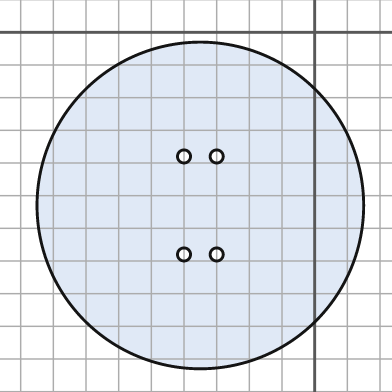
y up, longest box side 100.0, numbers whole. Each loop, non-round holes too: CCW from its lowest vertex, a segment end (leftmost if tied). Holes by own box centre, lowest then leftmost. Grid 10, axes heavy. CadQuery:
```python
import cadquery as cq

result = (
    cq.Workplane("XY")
    .moveTo(-35.0, -53.0)
    .circle(50.0)
    .moveTo(-40.0, -68.0)
    .circle(2.0)
    .moveTo(-30.0, -68.0)
    .circle(2.0)
    .moveTo(-40.0, -38.0)
    .circle(2.0)
    .moveTo(-30.0, -38.0)
    .circle(2.0)
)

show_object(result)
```